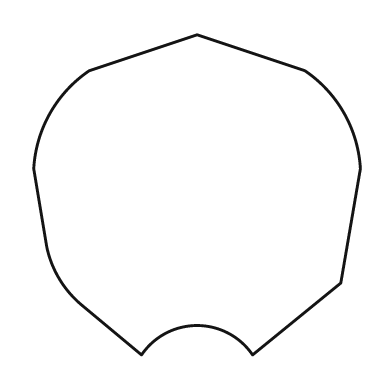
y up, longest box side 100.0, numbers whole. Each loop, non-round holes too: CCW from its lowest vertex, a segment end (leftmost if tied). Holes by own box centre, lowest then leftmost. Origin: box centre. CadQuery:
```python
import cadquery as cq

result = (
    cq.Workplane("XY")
    .moveTo(-17.0, -49.0)
    .threePointArc((0.0, -40.0), (17.0, -49.0))
    .lineTo(44.0, -27.0)
    .lineTo(50.0, 8.0)
    .threePointArc((45.0, 25.0), (33.0, 38.0))
    .lineTo(0.0, 49.0)
    .lineTo(-33.0, 38.0)
    .threePointArc((-45.0, 25.0), (-50.0, 8.0))
    .lineTo(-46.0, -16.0)
    .threePointArc((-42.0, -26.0), (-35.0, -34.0))
    .close()
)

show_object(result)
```